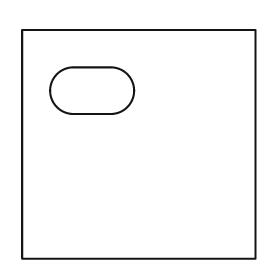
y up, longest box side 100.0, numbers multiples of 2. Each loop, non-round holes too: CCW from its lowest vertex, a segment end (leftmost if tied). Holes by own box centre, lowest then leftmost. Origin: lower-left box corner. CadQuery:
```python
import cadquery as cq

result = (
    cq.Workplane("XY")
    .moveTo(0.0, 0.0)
    .lineTo(100.0, 0.0)
    .lineTo(100.0, 98.0)
    .lineTo(0.0, 98.0)
    .close()
    .moveTo(22.0, 62.0)
    .lineTo(38.0, 62.0)
    .threePointArc((48.0, 72.0), (38.0, 82.0))
    .lineTo(22.0, 82.0)
    .threePointArc((12.0, 72.0), (22.0, 62.0))
    .close()
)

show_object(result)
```